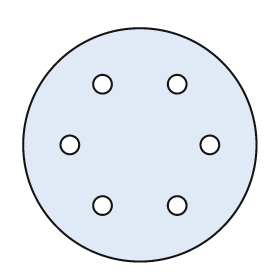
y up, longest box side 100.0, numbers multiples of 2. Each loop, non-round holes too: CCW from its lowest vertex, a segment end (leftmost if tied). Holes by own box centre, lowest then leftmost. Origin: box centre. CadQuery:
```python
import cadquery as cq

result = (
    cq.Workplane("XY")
    .moveTo(0.0, 0.0)
    .circle(50.0)
    .moveTo(-16.0, -26.0)
    .circle(4.0)
    .moveTo(16.0, -26.0)
    .circle(4.0)
    .moveTo(-30.0, 0.0)
    .circle(4.0)
    .moveTo(30.0, 0.0)
    .circle(4.0)
    .moveTo(-16.0, 26.0)
    .circle(4.0)
    .moveTo(16.0, 26.0)
    .circle(4.0)
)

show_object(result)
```